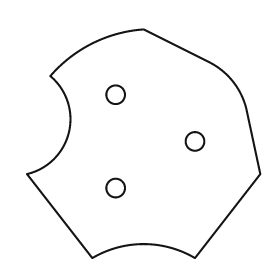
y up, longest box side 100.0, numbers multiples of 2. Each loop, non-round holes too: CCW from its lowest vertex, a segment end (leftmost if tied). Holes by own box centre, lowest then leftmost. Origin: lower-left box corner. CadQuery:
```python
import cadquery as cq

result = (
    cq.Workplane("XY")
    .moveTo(28.0, 0.0)
    .threePointArc((50.0, 6.0), (72.0, 0.0))
    .lineTo(100.0, 36.0)
    .lineTo(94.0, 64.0)
    .threePointArc((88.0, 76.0), (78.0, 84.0))
    .lineTo(50.0, 98.0)
    .threePointArc((28.0, 92.0), (10.0, 78.0))
    .threePointArc((18.0, 54.0), (0.0, 36.0))
    .close()
    .moveTo(38.0, 30.0)
    .circle(4.0)
    .moveTo(72.0, 50.0)
    .circle(4.0)
    .moveTo(38.0, 70.0)
    .circle(4.0)
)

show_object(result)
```